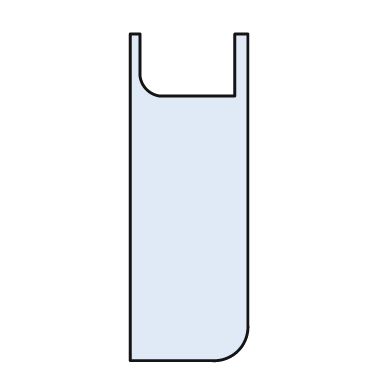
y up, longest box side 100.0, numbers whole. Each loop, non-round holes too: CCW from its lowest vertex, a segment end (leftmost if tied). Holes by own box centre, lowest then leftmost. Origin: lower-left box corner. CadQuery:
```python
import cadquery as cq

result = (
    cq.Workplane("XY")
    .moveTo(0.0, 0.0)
    .lineTo(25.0, 0.0)
    .threePointArc((33.0, 3.0), (36.0, 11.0))
    .lineTo(36.0, 100.0)
    .lineTo(32.0, 100.0)
    .lineTo(32.0, 81.0)
    .lineTo(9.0, 81.0)
    .threePointArc((5.0, 83.0), (3.0, 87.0))
    .lineTo(3.0, 100.0)
    .lineTo(0.0, 100.0)
    .close()
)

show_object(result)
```